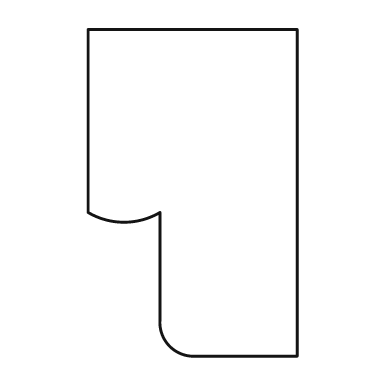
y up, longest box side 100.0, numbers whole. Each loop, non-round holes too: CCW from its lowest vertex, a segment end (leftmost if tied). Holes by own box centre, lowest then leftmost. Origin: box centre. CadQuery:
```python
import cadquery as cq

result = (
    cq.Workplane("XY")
    .moveTo(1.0, -50.0)
    .lineTo(32.0, -50.0)
    .lineTo(32.0, 50.0)
    .lineTo(-32.0, 50.0)
    .lineTo(-32.0, -6.0)
    .threePointArc((-21.0, -9.0), (-10.0, -6.0))
    .lineTo(-10.0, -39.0)
    .threePointArc((-7.0, -47.0), (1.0, -50.0))
    .close()
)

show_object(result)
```